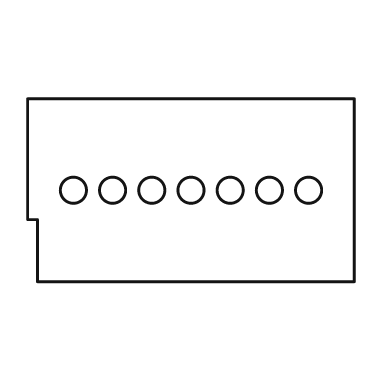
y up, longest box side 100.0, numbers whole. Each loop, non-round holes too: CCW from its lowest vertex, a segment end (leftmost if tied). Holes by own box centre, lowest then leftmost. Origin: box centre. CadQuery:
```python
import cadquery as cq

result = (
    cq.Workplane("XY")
    .moveTo(-47.0, -28.0)
    .lineTo(50.0, -28.0)
    .lineTo(50.0, 28.0)
    .lineTo(-50.0, 28.0)
    .lineTo(-50.0, -9.0)
    .lineTo(-47.0, -9.0)
    .close()
    .moveTo(-36.0, 0.0)
    .circle(4.0)
    .moveTo(-24.0, 0.0)
    .circle(4.0)
    .moveTo(-12.0, 0.0)
    .circle(4.0)
    .moveTo(0.0, 0.0)
    .circle(4.0)
    .moveTo(12.0, 0.0)
    .circle(4.0)
    .moveTo(24.0, 0.0)
    .circle(4.0)
    .moveTo(36.0, 0.0)
    .circle(4.0)
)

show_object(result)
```